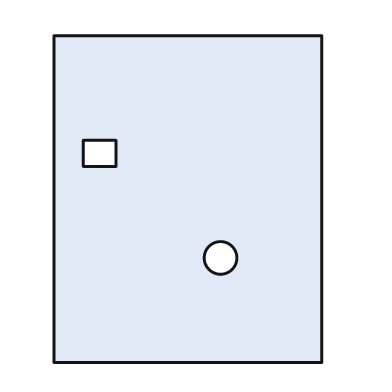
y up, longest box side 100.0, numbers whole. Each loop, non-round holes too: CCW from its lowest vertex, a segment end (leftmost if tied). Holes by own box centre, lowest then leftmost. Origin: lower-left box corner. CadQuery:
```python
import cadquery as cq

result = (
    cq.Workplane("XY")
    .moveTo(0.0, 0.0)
    .lineTo(82.0, 0.0)
    .lineTo(82.0, 100.0)
    .lineTo(0.0, 100.0)
    .close()
    .moveTo(51.0, 32.0)
    .circle(5.0)
    .moveTo(9.0, 60.0)
    .lineTo(19.0, 60.0)
    .lineTo(19.0, 68.0)
    .lineTo(9.0, 68.0)
    .close()
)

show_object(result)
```